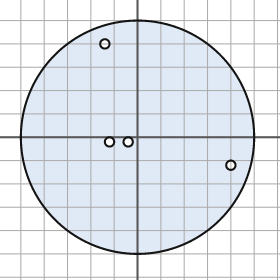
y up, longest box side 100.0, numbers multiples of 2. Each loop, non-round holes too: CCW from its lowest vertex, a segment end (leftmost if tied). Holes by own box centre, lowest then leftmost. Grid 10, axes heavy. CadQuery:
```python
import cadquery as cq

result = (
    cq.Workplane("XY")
    .moveTo(0.0, 0.0)
    .circle(50.0)
    .moveTo(40.0, -12.0)
    .circle(2.0)
    .moveTo(-12.0, -2.0)
    .circle(2.0)
    .moveTo(-4.0, -2.0)
    .circle(2.0)
    .moveTo(-14.0, 40.0)
    .circle(2.0)
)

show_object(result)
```